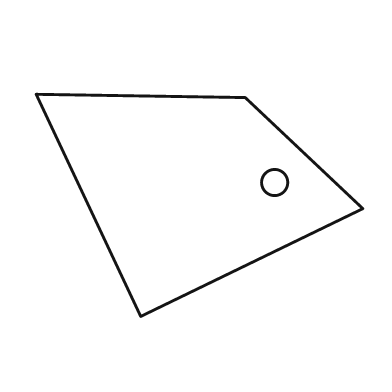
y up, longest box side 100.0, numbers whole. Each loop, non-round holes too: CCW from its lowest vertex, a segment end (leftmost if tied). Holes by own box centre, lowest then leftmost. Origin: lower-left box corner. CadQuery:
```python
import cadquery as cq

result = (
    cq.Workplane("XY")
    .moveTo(32.0, 0.0)
    .lineTo(100.0, 33.0)
    .lineTo(64.0, 67.0)
    .lineTo(0.0, 68.0)
    .close()
    .moveTo(73.0, 41.0)
    .circle(4.0)
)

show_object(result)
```